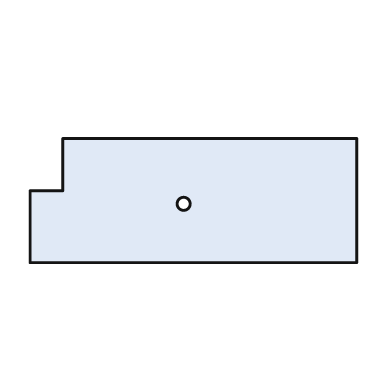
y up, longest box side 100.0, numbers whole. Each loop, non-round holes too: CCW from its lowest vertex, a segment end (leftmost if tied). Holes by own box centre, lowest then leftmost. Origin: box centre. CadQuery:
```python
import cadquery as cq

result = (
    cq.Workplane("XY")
    .moveTo(-50.0, -19.0)
    .lineTo(50.0, -19.0)
    .lineTo(50.0, 19.0)
    .lineTo(-40.0, 19.0)
    .lineTo(-40.0, 3.0)
    .lineTo(-50.0, 3.0)
    .close()
    .moveTo(-3.0, -1.0)
    .circle(2.0)
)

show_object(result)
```